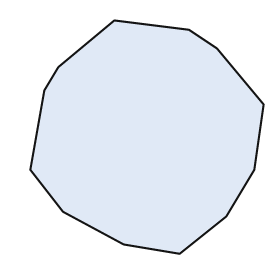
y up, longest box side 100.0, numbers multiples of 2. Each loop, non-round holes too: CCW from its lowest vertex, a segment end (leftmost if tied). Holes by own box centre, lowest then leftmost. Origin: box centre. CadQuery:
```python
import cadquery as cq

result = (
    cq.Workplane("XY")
    .moveTo(14.0, -50.0)
    .lineTo(34.0, -34.0)
    .lineTo(46.0, -14.0)
    .lineTo(50.0, 14.0)
    .lineTo(30.0, 38.0)
    .lineTo(18.0, 46.0)
    .lineTo(-14.0, 50.0)
    .lineTo(-38.0, 30.0)
    .lineTo(-44.0, 20.0)
    .lineTo(-50.0, -14.0)
    .lineTo(-36.0, -32.0)
    .lineTo(-10.0, -46.0)
    .close()
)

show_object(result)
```